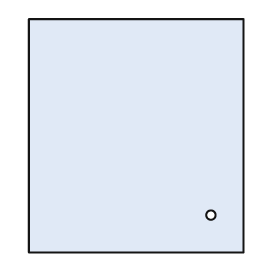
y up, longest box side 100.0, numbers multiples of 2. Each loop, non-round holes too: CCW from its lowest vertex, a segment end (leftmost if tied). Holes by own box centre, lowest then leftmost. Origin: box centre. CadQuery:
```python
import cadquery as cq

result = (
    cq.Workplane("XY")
    .moveTo(-46.0, -50.0)
    .lineTo(46.0, -50.0)
    .lineTo(46.0, 50.0)
    .lineTo(-46.0, 50.0)
    .close()
    .moveTo(32.0, -34.0)
    .circle(2.0)
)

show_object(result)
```